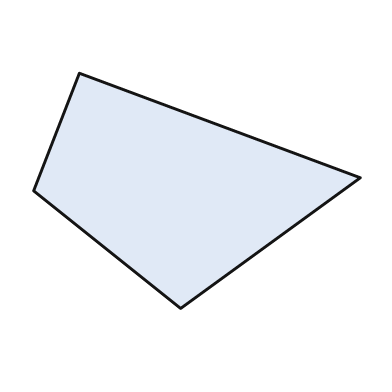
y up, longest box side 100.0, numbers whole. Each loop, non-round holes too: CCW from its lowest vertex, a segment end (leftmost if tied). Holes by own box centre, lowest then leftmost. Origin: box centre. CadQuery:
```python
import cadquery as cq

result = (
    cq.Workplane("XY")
    .moveTo(-5.0, -36.0)
    .lineTo(50.0, 4.0)
    .lineTo(-36.0, 36.0)
    .lineTo(-50.0, 0.0)
    .close()
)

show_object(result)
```